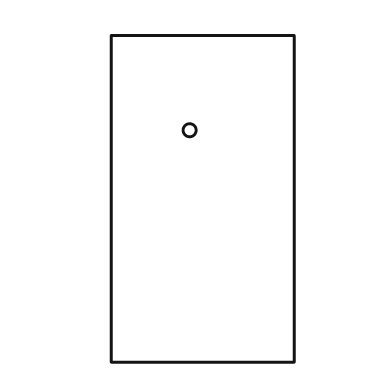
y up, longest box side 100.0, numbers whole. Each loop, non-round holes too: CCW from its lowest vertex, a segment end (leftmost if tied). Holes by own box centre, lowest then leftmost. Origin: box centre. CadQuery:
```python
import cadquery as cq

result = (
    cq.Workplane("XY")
    .moveTo(-28.0, -50.0)
    .lineTo(28.0, -50.0)
    .lineTo(28.0, 50.0)
    .lineTo(-28.0, 50.0)
    .close()
    .moveTo(-4.0, 21.0)
    .circle(2.0)
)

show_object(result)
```